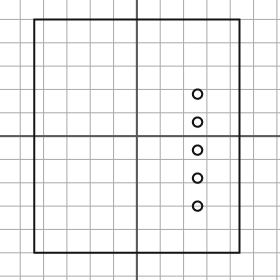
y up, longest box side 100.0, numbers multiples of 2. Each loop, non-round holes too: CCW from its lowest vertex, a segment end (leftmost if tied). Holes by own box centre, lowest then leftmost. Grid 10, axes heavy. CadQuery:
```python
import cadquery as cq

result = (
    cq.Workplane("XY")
    .moveTo(-44.0, -50.0)
    .lineTo(44.0, -50.0)
    .lineTo(44.0, 50.0)
    .lineTo(-44.0, 50.0)
    .close()
    .moveTo(26.0, -30.0)
    .circle(2.0)
    .moveTo(26.0, -18.0)
    .circle(2.0)
    .moveTo(26.0, -6.0)
    .circle(2.0)
    .moveTo(26.0, 6.0)
    .circle(2.0)
    .moveTo(26.0, 18.0)
    .circle(2.0)
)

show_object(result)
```